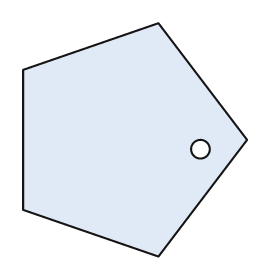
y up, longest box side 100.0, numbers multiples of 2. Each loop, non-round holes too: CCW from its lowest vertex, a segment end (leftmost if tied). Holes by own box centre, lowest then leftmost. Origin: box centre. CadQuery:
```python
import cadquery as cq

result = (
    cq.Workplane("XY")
    .moveTo(10.0, -50.0)
    .lineTo(48.0, 0.0)
    .lineTo(10.0, 50.0)
    .lineTo(-48.0, 30.0)
    .lineTo(-48.0, -30.0)
    .close()
    .moveTo(28.0, -4.0)
    .circle(4.0)
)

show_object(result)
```